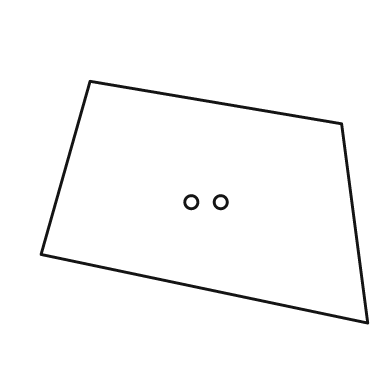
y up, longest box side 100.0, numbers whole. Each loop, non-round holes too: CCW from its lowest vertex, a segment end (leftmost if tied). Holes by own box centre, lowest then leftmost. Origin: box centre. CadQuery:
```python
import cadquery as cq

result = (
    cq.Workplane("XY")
    .moveTo(50.0, -37.0)
    .lineTo(42.0, 24.0)
    .lineTo(-35.0, 37.0)
    .lineTo(-50.0, -16.0)
    .close()
    .moveTo(-4.0, 0.0)
    .circle(2.0)
    .moveTo(5.0, 0.0)
    .circle(2.0)
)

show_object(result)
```